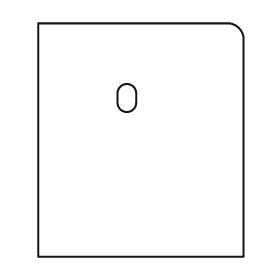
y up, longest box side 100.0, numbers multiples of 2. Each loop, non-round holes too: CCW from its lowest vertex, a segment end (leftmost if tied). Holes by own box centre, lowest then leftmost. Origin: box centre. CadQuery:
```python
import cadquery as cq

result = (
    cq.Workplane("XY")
    .moveTo(-44.0, -50.0)
    .lineTo(44.0, -50.0)
    .lineTo(44.0, 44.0)
    .threePointArc((42.0, 48.0), (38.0, 50.0))
    .lineTo(-44.0, 50.0)
    .close()
    .moveTo(-10.0, 16.0)
    .threePointArc((-6.0, 12.0), (-2.0, 16.0))
    .lineTo(-2.0, 20.0)
    .threePointArc((-6.0, 24.0), (-10.0, 20.0))
    .close()
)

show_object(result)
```